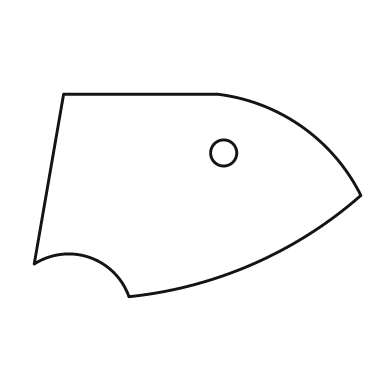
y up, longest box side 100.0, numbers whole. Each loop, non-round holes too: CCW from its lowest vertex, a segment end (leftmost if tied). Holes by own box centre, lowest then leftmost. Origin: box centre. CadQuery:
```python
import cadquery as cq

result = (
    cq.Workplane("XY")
    .moveTo(-21.0, -31.0)
    .threePointArc((17.0, -21.0), (50.0, 0.0))
    .threePointArc((32.0, 21.0), (6.0, 31.0))
    .lineTo(-41.0, 31.0)
    .lineTo(-50.0, -21.0)
    .threePointArc((-33.0, -19.0), (-21.0, -31.0))
    .close()
    .moveTo(8.0, 13.0)
    .circle(4.0)
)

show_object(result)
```